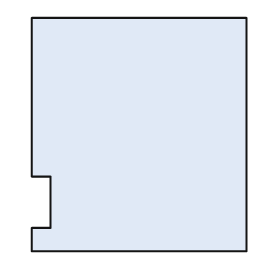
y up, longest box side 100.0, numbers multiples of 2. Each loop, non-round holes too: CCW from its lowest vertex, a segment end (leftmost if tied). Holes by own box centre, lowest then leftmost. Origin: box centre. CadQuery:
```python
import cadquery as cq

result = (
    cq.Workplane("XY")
    .moveTo(-46.0, -50.0)
    .lineTo(46.0, -50.0)
    .lineTo(46.0, 50.0)
    .lineTo(-46.0, 50.0)
    .lineTo(-46.0, -18.0)
    .lineTo(-38.0, -18.0)
    .lineTo(-38.0, -40.0)
    .lineTo(-46.0, -40.0)
    .close()
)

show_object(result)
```